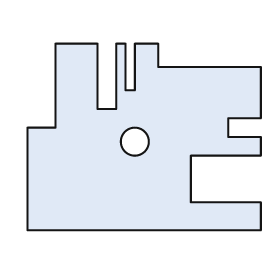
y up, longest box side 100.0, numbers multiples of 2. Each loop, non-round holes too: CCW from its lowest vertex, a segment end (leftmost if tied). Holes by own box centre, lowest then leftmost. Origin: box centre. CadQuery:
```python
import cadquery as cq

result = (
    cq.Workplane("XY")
    .moveTo(-50.0, -40.0)
    .lineTo(50.0, -40.0)
    .lineTo(50.0, -28.0)
    .lineTo(20.0, -28.0)
    .lineTo(20.0, -8.0)
    .lineTo(50.0, -8.0)
    .lineTo(50.0, 0.0)
    .lineTo(36.0, 0.0)
    .lineTo(36.0, 8.0)
    .lineTo(50.0, 8.0)
    .lineTo(50.0, 30.0)
    .lineTo(6.0, 30.0)
    .lineTo(6.0, 40.0)
    .lineTo(-4.0, 40.0)
    .lineTo(-4.0, 20.0)
    .lineTo(-8.0, 20.0)
    .lineTo(-8.0, 40.0)
    .lineTo(-12.0, 40.0)
    .lineTo(-12.0, 12.0)
    .lineTo(-20.0, 12.0)
    .lineTo(-20.0, 40.0)
    .lineTo(-38.0, 40.0)
    .lineTo(-38.0, 4.0)
    .lineTo(-50.0, 4.0)
    .close()
    .moveTo(-4.0, -2.0)
    .circle(6.0)
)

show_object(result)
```